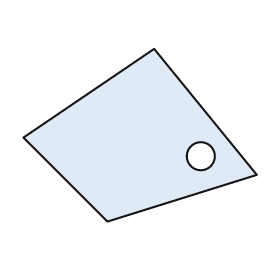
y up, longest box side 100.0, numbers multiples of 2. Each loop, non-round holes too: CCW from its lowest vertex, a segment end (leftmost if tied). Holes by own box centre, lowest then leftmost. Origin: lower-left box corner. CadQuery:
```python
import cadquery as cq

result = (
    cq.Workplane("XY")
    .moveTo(36.0, 0.0)
    .lineTo(100.0, 20.0)
    .lineTo(56.0, 74.0)
    .lineTo(0.0, 36.0)
    .close()
    .moveTo(76.0, 28.0)
    .circle(6.0)
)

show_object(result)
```